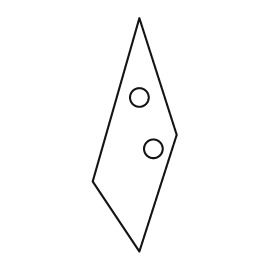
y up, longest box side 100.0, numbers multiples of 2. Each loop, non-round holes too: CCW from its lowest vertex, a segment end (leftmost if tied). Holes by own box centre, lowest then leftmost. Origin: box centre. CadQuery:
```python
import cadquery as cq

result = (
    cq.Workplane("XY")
    .moveTo(2.0, -50.0)
    .lineTo(18.0, 0.0)
    .lineTo(2.0, 50.0)
    .lineTo(-18.0, -20.0)
    .close()
    .moveTo(8.0, -6.0)
    .circle(4.0)
    .moveTo(2.0, 16.0)
    .circle(4.0)
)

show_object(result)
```